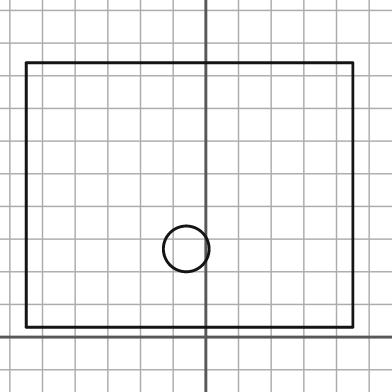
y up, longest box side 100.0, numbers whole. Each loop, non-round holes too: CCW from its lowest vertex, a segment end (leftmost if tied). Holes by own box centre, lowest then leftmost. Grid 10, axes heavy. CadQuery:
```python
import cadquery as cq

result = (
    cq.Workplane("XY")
    .moveTo(-55.0, 3.0)
    .lineTo(45.0, 3.0)
    .lineTo(45.0, 84.0)
    .lineTo(-55.0, 84.0)
    .close()
    .moveTo(-6.0, 27.0)
    .circle(7.0)
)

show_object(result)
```